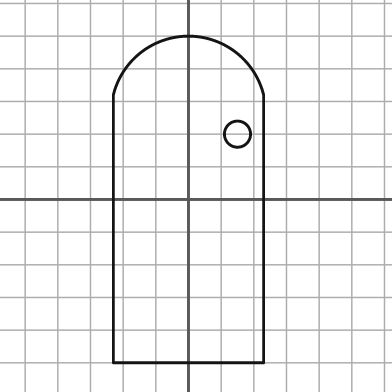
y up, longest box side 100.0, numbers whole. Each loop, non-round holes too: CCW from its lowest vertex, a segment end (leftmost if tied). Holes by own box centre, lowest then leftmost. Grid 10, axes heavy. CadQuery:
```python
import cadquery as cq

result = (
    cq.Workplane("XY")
    .moveTo(-23.0, -50.0)
    .lineTo(23.0, -50.0)
    .lineTo(23.0, 32.0)
    .threePointArc((0.0, 50.0), (-23.0, 32.0))
    .close()
    .moveTo(15.0, 20.0)
    .circle(4.0)
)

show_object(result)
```